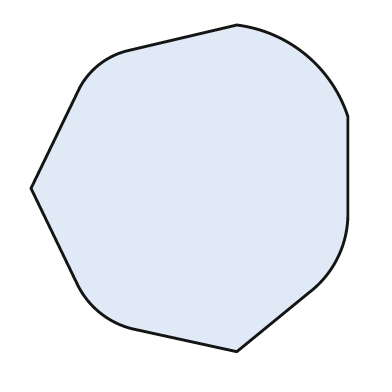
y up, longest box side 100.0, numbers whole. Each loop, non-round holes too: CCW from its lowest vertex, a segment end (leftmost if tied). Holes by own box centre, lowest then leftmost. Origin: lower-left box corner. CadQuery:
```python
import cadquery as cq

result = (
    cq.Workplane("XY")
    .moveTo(63.0, 0.0)
    .lineTo(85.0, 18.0)
    .threePointArc((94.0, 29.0), (97.0, 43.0))
    .lineTo(97.0, 72.0)
    .threePointArc((84.0, 91.0), (63.0, 100.0))
    .lineTo(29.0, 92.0)
    .threePointArc((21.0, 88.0), (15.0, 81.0))
    .lineTo(0.0, 50.0)
    .lineTo(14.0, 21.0)
    .threePointArc((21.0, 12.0), (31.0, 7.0))
    .close()
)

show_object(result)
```